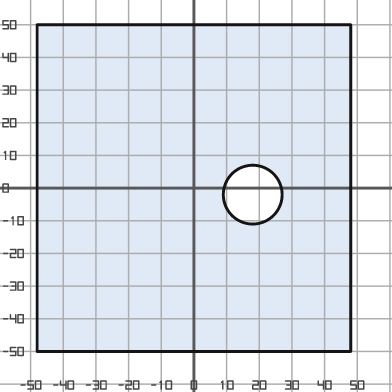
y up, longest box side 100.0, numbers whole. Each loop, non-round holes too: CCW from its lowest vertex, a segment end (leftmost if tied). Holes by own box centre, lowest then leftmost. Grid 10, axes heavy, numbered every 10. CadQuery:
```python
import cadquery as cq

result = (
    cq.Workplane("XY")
    .moveTo(-48.0, -50.0)
    .lineTo(48.0, -50.0)
    .lineTo(48.0, 50.0)
    .lineTo(-48.0, 50.0)
    .close()
    .moveTo(18.0, -2.0)
    .circle(9.0)
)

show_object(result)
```